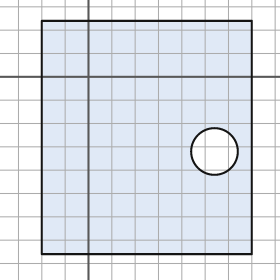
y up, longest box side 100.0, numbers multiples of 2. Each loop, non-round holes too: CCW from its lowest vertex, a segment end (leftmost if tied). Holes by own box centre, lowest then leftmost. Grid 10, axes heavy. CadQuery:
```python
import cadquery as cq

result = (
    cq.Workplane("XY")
    .moveTo(-20.0, -76.0)
    .lineTo(70.0, -76.0)
    .lineTo(70.0, 24.0)
    .lineTo(-20.0, 24.0)
    .close()
    .moveTo(54.0, -32.0)
    .circle(10.0)
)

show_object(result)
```